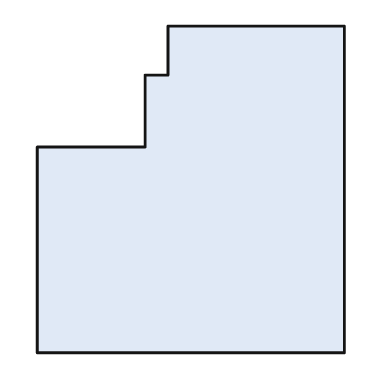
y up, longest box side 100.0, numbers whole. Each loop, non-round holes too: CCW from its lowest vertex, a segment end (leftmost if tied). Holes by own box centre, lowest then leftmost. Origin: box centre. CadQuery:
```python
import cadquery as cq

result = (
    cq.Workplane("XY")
    .moveTo(-47.0, -50.0)
    .lineTo(47.0, -50.0)
    .lineTo(47.0, 50.0)
    .lineTo(-7.0, 50.0)
    .lineTo(-7.0, 35.0)
    .lineTo(-14.0, 35.0)
    .lineTo(-14.0, 13.0)
    .lineTo(-47.0, 13.0)
    .close()
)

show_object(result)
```